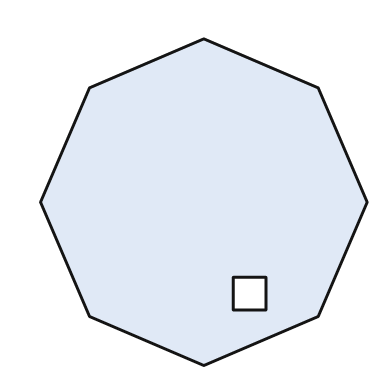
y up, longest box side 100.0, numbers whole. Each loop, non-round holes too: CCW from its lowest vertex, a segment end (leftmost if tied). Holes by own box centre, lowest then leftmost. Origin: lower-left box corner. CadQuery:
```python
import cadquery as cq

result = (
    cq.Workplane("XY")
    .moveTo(50.0, 0.0)
    .lineTo(85.0, 15.0)
    .lineTo(100.0, 50.0)
    .lineTo(85.0, 85.0)
    .lineTo(50.0, 100.0)
    .lineTo(15.0, 85.0)
    .lineTo(0.0, 50.0)
    .lineTo(15.0, 15.0)
    .close()
    .moveTo(59.0, 17.0)
    .lineTo(69.0, 17.0)
    .lineTo(69.0, 27.0)
    .lineTo(59.0, 27.0)
    .close()
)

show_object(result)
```